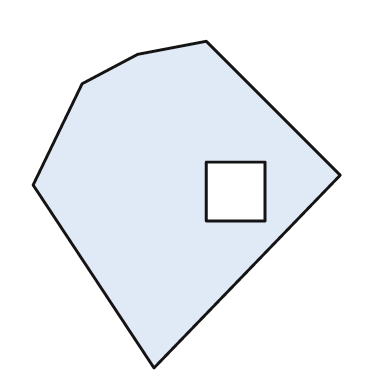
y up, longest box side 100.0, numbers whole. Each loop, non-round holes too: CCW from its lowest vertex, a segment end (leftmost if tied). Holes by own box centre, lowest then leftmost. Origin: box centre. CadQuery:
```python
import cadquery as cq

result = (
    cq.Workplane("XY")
    .moveTo(-10.0, -50.0)
    .lineTo(47.0, 9.0)
    .lineTo(6.0, 50.0)
    .lineTo(-15.0, 46.0)
    .lineTo(-32.0, 37.0)
    .lineTo(-47.0, 6.0)
    .close()
    .moveTo(6.0, -5.0)
    .lineTo(24.0, -5.0)
    .lineTo(24.0, 13.0)
    .lineTo(6.0, 13.0)
    .close()
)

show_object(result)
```